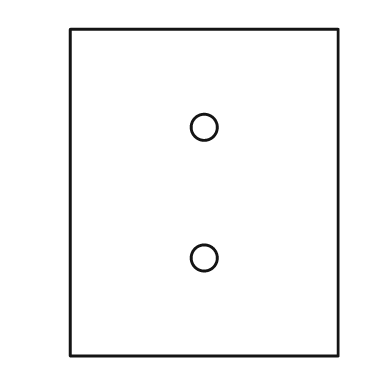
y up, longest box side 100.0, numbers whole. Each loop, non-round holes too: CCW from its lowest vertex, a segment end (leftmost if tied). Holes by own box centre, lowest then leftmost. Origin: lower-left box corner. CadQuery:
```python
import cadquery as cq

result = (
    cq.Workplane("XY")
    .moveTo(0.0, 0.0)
    .lineTo(82.0, 0.0)
    .lineTo(82.0, 100.0)
    .lineTo(0.0, 100.0)
    .close()
    .moveTo(41.0, 30.0)
    .circle(4.0)
    .moveTo(41.0, 70.0)
    .circle(4.0)
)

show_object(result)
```